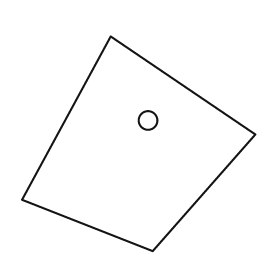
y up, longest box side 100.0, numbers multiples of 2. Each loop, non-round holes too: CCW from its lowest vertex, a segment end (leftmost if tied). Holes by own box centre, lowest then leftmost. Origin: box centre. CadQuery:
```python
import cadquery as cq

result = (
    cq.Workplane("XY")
    .moveTo(6.0, -46.0)
    .lineTo(50.0, 4.0)
    .lineTo(-12.0, 46.0)
    .lineTo(-50.0, -24.0)
    .close()
    .moveTo(4.0, 10.0)
    .circle(4.0)
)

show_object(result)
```